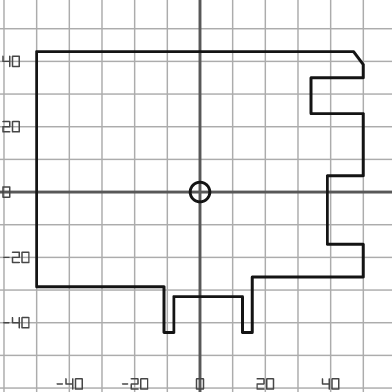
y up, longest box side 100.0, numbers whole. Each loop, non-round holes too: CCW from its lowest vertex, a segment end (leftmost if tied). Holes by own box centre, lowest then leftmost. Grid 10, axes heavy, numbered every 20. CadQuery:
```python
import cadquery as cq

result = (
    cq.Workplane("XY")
    .moveTo(-11.0, -43.0)
    .lineTo(-8.0, -43.0)
    .lineTo(-8.0, -32.0)
    .lineTo(13.0, -32.0)
    .lineTo(13.0, -43.0)
    .lineTo(16.0, -43.0)
    .lineTo(16.0, -26.0)
    .lineTo(50.0, -26.0)
    .lineTo(50.0, -16.0)
    .lineTo(39.0, -16.0)
    .lineTo(39.0, 5.0)
    .lineTo(50.0, 5.0)
    .lineTo(50.0, 24.0)
    .lineTo(34.0, 24.0)
    .lineTo(34.0, 35.0)
    .lineTo(50.0, 35.0)
    .lineTo(50.0, 39.0)
    .lineTo(47.0, 43.0)
    .lineTo(-50.0, 43.0)
    .lineTo(-50.0, -29.0)
    .lineTo(-11.0, -29.0)
    .close()
    .moveTo(0.0, 0.0)
    .circle(3.0)
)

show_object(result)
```